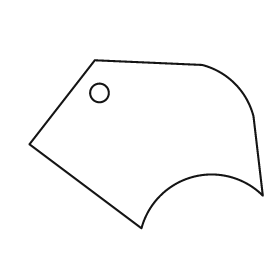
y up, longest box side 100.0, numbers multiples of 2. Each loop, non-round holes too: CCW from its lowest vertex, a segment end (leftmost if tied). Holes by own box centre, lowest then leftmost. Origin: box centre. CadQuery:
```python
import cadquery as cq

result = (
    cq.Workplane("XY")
    .moveTo(-2.0, -36.0)
    .threePointArc((20.0, -14.0), (50.0, -22.0))
    .lineTo(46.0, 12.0)
    .threePointArc((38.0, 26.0), (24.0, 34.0))
    .lineTo(-22.0, 36.0)
    .lineTo(-50.0, 0.0)
    .close()
    .moveTo(-20.0, 22.0)
    .circle(4.0)
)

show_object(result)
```